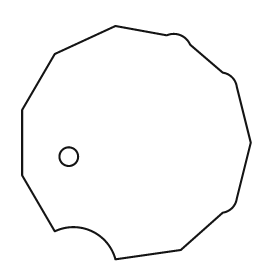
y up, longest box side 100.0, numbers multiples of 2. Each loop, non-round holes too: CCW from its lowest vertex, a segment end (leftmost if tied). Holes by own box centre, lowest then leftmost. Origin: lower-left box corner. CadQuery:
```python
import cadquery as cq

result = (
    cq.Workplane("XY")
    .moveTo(40.0, 0.0)
    .lineTo(68.0, 4.0)
    .lineTo(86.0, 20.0)
    .threePointArc((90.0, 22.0), (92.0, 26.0))
    .lineTo(98.0, 50.0)
    .lineTo(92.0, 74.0)
    .threePointArc((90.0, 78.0), (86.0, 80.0))
    .lineTo(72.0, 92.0)
    .threePointArc((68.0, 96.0), (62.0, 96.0))
    .lineTo(40.0, 100.0)
    .lineTo(14.0, 88.0)
    .lineTo(0.0, 64.0)
    .lineTo(0.0, 36.0)
    .lineTo(14.0, 12.0)
    .threePointArc((30.0, 12.0), (40.0, 0.0))
    .close()
    .moveTo(20.0, 44.0)
    .circle(4.0)
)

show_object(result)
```